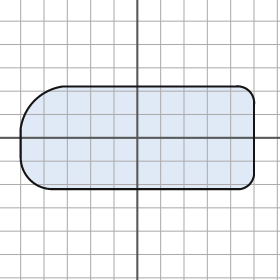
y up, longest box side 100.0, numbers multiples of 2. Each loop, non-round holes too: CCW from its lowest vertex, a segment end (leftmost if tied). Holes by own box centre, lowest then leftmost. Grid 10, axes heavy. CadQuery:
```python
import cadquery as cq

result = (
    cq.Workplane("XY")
    .moveTo(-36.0, -22.0)
    .lineTo(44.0, -22.0)
    .threePointArc((48.0, -20.0), (50.0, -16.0))
    .lineTo(50.0, 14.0)
    .threePointArc((48.0, 20.0), (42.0, 22.0))
    .lineTo(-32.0, 22.0)
    .threePointArc((-44.0, 16.0), (-50.0, 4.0))
    .lineTo(-50.0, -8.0)
    .threePointArc((-46.0, -18.0), (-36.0, -22.0))
    .close()
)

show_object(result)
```